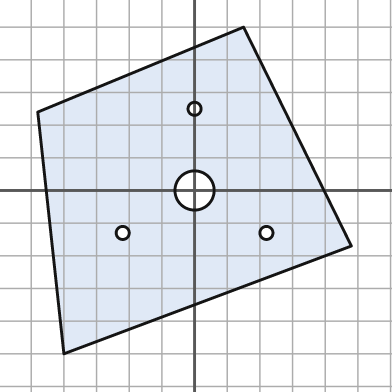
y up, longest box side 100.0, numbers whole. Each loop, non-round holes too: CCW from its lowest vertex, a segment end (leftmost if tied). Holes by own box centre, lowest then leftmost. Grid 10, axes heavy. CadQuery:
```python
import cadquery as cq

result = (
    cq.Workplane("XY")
    .moveTo(-40.0, -50.0)
    .lineTo(48.0, -17.0)
    .lineTo(15.0, 50.0)
    .lineTo(-48.0, 24.0)
    .close()
    .moveTo(-22.0, -13.0)
    .circle(2.0)
    .moveTo(22.0, -13.0)
    .circle(2.0)
    .moveTo(0.0, 0.0)
    .circle(6.0)
    .moveTo(0.0, 25.0)
    .circle(2.0)
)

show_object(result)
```